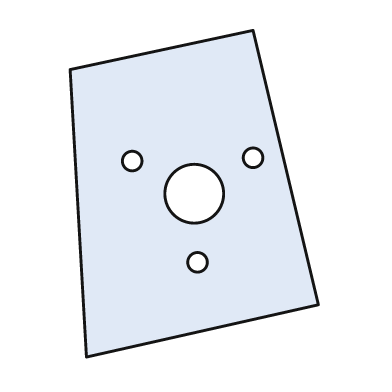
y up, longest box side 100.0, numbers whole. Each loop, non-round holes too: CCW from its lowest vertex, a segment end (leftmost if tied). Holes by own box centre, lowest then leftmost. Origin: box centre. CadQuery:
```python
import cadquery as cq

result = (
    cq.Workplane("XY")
    .moveTo(-33.0, -50.0)
    .lineTo(38.0, -34.0)
    .lineTo(18.0, 50.0)
    .lineTo(-38.0, 38.0)
    .close()
    .moveTo(1.0, -21.0)
    .circle(3.0)
    .moveTo(0.0, 0.0)
    .circle(9.0)
    .moveTo(-19.0, 10.0)
    .circle(3.0)
    .moveTo(18.0, 11.0)
    .circle(3.0)
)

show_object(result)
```